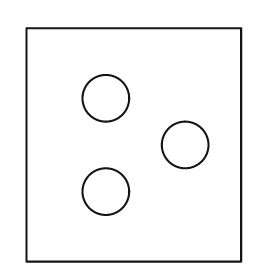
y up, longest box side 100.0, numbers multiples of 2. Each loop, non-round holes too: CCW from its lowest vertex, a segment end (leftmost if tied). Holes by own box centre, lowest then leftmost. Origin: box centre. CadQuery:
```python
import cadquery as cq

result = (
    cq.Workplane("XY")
    .moveTo(-46.0, -50.0)
    .lineTo(46.0, -50.0)
    .lineTo(46.0, 50.0)
    .lineTo(-46.0, 50.0)
    .close()
    .moveTo(-12.0, -20.0)
    .circle(10.0)
    .moveTo(22.0, 0.0)
    .circle(10.0)
    .moveTo(-12.0, 20.0)
    .circle(10.0)
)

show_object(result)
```